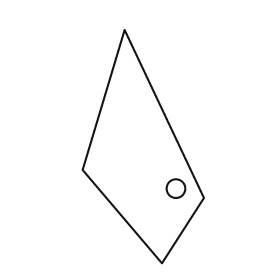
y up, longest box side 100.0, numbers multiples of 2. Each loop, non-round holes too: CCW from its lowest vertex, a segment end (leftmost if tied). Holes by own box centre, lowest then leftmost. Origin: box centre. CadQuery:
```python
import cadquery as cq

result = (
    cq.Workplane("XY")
    .moveTo(8.0, -50.0)
    .lineTo(26.0, -22.0)
    .lineTo(-8.0, 50.0)
    .lineTo(-26.0, -10.0)
    .close()
    .moveTo(14.0, -18.0)
    .circle(4.0)
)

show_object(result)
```